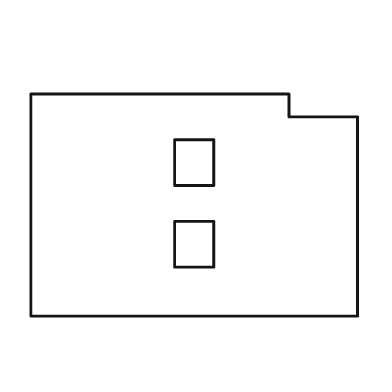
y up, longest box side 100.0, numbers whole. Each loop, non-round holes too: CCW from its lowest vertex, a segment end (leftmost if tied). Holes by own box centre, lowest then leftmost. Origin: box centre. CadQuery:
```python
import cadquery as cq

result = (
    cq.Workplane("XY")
    .moveTo(-50.0, -34.0)
    .lineTo(50.0, -34.0)
    .lineTo(50.0, 27.0)
    .lineTo(29.0, 27.0)
    .lineTo(29.0, 34.0)
    .lineTo(-50.0, 34.0)
    .close()
    .moveTo(-6.0, -19.0)
    .lineTo(6.0, -19.0)
    .lineTo(6.0, -5.0)
    .lineTo(-6.0, -5.0)
    .close()
    .moveTo(-6.0, 6.0)
    .lineTo(6.0, 6.0)
    .lineTo(6.0, 20.0)
    .lineTo(-6.0, 20.0)
    .close()
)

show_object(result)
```